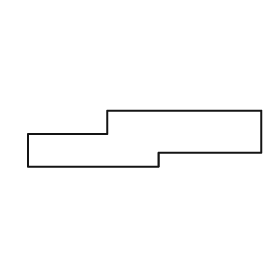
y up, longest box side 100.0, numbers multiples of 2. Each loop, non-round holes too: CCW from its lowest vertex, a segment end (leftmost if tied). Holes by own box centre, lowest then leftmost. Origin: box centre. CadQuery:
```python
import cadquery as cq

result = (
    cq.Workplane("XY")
    .moveTo(-50.0, -12.0)
    .lineTo(6.0, -12.0)
    .lineTo(6.0, -6.0)
    .lineTo(50.0, -6.0)
    .lineTo(50.0, 12.0)
    .lineTo(-16.0, 12.0)
    .lineTo(-16.0, 2.0)
    .lineTo(-50.0, 2.0)
    .close()
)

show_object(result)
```